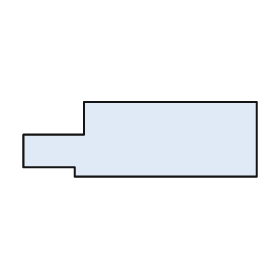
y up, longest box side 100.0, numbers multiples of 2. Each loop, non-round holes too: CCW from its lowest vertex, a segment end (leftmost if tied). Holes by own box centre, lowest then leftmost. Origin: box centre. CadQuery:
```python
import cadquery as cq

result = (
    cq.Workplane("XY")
    .moveTo(-28.0, -16.0)
    .lineTo(50.0, -16.0)
    .lineTo(50.0, 16.0)
    .lineTo(-24.0, 16.0)
    .lineTo(-24.0, 2.0)
    .lineTo(-50.0, 2.0)
    .lineTo(-50.0, -12.0)
    .lineTo(-28.0, -12.0)
    .close()
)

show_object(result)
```